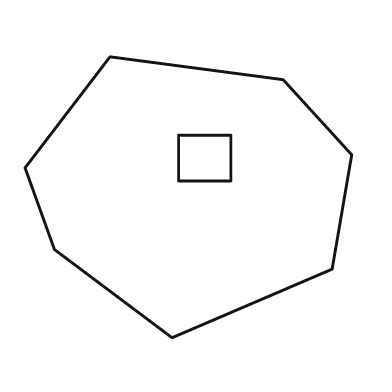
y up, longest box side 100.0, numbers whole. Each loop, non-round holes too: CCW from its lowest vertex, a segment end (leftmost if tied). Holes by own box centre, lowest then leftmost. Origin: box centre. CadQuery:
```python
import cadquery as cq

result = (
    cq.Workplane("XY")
    .moveTo(-5.0, -43.0)
    .lineTo(44.0, -22.0)
    .lineTo(50.0, 13.0)
    .lineTo(29.0, 36.0)
    .lineTo(-24.0, 43.0)
    .lineTo(-50.0, 9.0)
    .lineTo(-41.0, -16.0)
    .close()
    .moveTo(-3.0, 5.0)
    .lineTo(13.0, 5.0)
    .lineTo(13.0, 19.0)
    .lineTo(-3.0, 19.0)
    .close()
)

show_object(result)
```